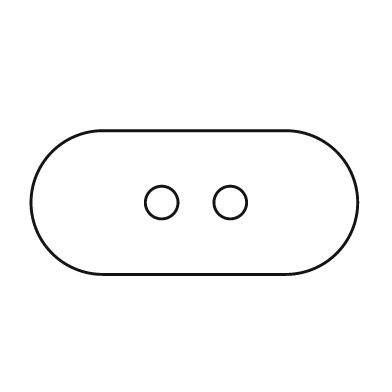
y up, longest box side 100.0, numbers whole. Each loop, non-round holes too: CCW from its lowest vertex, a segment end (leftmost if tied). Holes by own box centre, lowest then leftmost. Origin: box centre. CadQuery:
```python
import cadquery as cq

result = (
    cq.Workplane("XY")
    .moveTo(-28.0, -22.0)
    .lineTo(28.0, -22.0)
    .threePointArc((50.0, 0.0), (28.0, 22.0))
    .lineTo(-28.0, 22.0)
    .threePointArc((-50.0, 0.0), (-28.0, -22.0))
    .close()
    .moveTo(-10.0, 0.0)
    .circle(5.0)
    .moveTo(11.0, 0.0)
    .circle(5.0)
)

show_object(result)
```